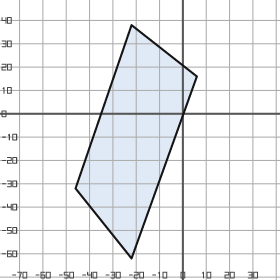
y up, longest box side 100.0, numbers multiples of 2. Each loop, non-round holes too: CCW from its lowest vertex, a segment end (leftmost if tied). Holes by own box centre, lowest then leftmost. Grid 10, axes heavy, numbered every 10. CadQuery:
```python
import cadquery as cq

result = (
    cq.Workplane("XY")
    .moveTo(-22.0, -62.0)
    .lineTo(6.0, 16.0)
    .lineTo(-22.0, 38.0)
    .lineTo(-46.0, -32.0)
    .close()
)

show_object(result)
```